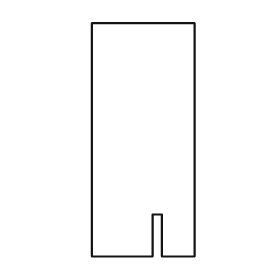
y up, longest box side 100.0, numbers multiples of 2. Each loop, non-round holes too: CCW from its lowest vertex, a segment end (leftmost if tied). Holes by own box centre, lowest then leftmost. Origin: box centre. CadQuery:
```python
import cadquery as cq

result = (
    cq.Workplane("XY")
    .moveTo(-22.0, -50.0)
    .lineTo(4.0, -50.0)
    .lineTo(4.0, -32.0)
    .lineTo(8.0, -32.0)
    .lineTo(8.0, -50.0)
    .lineTo(22.0, -50.0)
    .lineTo(22.0, 50.0)
    .lineTo(-22.0, 50.0)
    .close()
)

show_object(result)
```